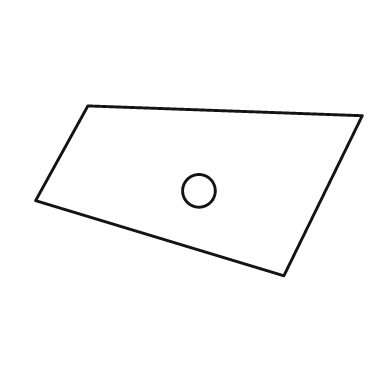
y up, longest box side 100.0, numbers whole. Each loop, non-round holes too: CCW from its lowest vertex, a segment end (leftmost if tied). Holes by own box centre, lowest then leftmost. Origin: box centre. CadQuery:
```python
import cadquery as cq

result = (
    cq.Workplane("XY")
    .moveTo(26.0, -26.0)
    .lineTo(50.0, 23.0)
    .lineTo(-34.0, 26.0)
    .lineTo(-50.0, -3.0)
    .close()
    .moveTo(0.0, 0.0)
    .circle(5.0)
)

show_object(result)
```